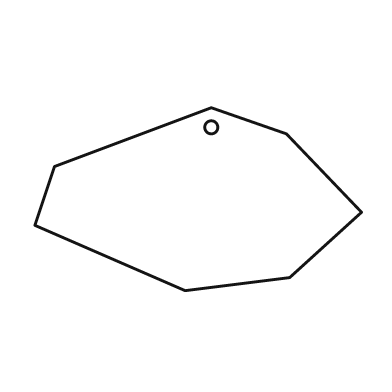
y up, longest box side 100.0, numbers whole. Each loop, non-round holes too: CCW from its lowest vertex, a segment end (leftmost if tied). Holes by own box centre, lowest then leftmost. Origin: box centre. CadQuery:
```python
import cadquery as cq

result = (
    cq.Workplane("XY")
    .moveTo(-4.0, -28.0)
    .lineTo(28.0, -24.0)
    .lineTo(50.0, -4.0)
    .lineTo(27.0, 20.0)
    .lineTo(4.0, 28.0)
    .lineTo(-44.0, 10.0)
    .lineTo(-50.0, -8.0)
    .close()
    .moveTo(4.0, 22.0)
    .circle(2.0)
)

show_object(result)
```